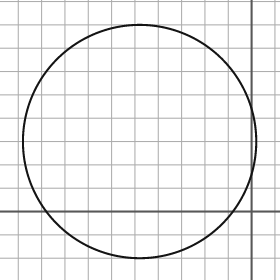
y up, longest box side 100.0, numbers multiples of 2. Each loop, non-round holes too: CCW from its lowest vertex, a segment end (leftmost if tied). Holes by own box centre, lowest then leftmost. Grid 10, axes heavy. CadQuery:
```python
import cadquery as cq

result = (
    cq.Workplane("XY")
    .moveTo(-48.0, 30.0)
    .circle(50.0)
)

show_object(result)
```